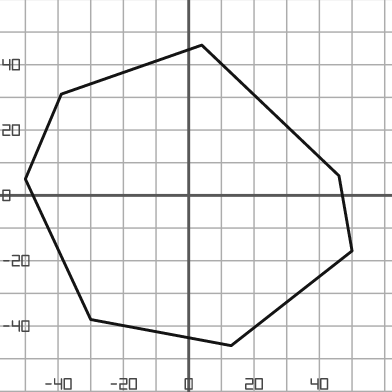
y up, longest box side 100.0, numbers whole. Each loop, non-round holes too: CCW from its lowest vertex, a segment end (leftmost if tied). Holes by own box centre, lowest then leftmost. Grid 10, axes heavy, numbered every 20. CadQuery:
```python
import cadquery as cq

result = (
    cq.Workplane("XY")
    .moveTo(13.0, -46.0)
    .lineTo(50.0, -17.0)
    .lineTo(46.0, 6.0)
    .lineTo(4.0, 46.0)
    .lineTo(-39.0, 31.0)
    .lineTo(-50.0, 5.0)
    .lineTo(-30.0, -38.0)
    .close()
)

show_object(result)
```